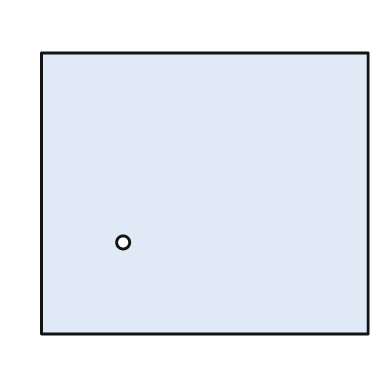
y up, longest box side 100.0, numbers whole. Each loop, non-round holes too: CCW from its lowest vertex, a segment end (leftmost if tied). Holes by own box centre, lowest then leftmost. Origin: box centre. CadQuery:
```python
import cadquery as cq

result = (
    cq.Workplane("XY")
    .moveTo(-50.0, -43.0)
    .lineTo(50.0, -43.0)
    .lineTo(50.0, 43.0)
    .lineTo(-50.0, 43.0)
    .close()
    .moveTo(-25.0, -15.0)
    .circle(2.0)
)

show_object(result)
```